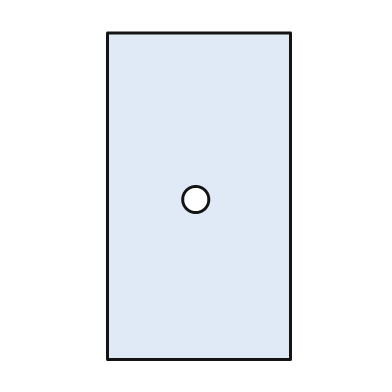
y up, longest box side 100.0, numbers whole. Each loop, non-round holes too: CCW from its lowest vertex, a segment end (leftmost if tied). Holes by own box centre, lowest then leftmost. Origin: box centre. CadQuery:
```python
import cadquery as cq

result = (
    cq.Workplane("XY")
    .moveTo(-28.0, -50.0)
    .lineTo(28.0, -50.0)
    .lineTo(28.0, 50.0)
    .lineTo(-28.0, 50.0)
    .close()
    .moveTo(-1.0, -1.0)
    .circle(4.0)
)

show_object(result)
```